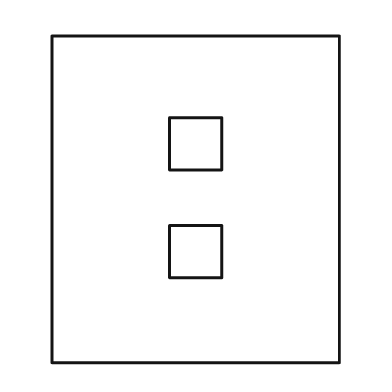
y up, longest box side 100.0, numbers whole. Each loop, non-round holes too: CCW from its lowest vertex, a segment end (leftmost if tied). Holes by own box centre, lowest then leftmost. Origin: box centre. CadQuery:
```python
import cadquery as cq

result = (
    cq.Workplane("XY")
    .moveTo(-44.0, -50.0)
    .lineTo(44.0, -50.0)
    .lineTo(44.0, 50.0)
    .lineTo(-44.0, 50.0)
    .close()
    .moveTo(-8.0, -24.0)
    .lineTo(8.0, -24.0)
    .lineTo(8.0, -8.0)
    .lineTo(-8.0, -8.0)
    .close()
    .moveTo(-8.0, 9.0)
    .lineTo(8.0, 9.0)
    .lineTo(8.0, 25.0)
    .lineTo(-8.0, 25.0)
    .close()
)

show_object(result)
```